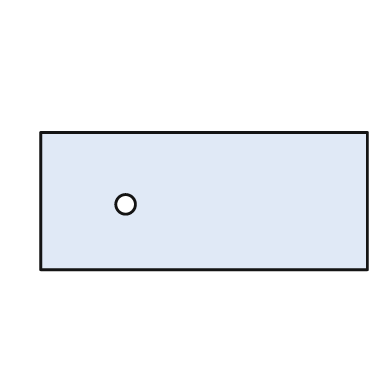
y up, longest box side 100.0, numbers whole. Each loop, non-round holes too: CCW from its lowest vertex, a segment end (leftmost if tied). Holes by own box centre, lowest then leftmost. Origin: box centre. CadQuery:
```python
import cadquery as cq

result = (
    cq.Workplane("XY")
    .moveTo(-50.0, -21.0)
    .lineTo(50.0, -21.0)
    .lineTo(50.0, 21.0)
    .lineTo(-50.0, 21.0)
    .close()
    .moveTo(-24.0, -1.0)
    .circle(3.0)
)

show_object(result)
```